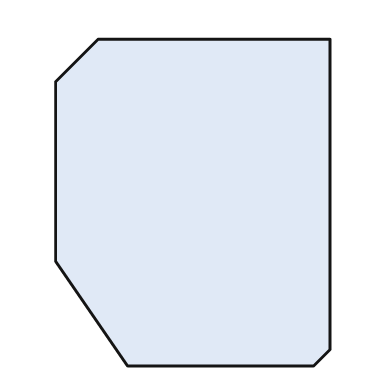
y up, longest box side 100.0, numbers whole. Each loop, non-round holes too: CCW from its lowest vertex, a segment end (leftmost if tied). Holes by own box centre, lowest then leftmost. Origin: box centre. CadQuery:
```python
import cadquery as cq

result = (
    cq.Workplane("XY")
    .moveTo(-20.0, -50.0)
    .lineTo(37.0, -50.0)
    .lineTo(42.0, -45.0)
    .lineTo(42.0, 50.0)
    .lineTo(-29.0, 50.0)
    .lineTo(-42.0, 37.0)
    .lineTo(-42.0, -18.0)
    .close()
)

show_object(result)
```